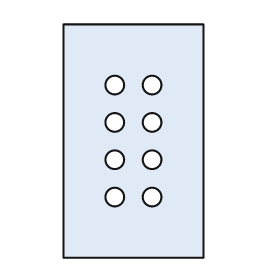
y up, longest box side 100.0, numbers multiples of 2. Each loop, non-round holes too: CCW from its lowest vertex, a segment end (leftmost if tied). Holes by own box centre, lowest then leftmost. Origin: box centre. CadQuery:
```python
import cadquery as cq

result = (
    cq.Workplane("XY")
    .moveTo(-30.0, -50.0)
    .lineTo(30.0, -50.0)
    .lineTo(30.0, 50.0)
    .lineTo(-30.0, 50.0)
    .close()
    .moveTo(-8.0, -24.0)
    .circle(4.0)
    .moveTo(8.0, -24.0)
    .circle(4.0)
    .moveTo(-8.0, -8.0)
    .circle(4.0)
    .moveTo(8.0, -8.0)
    .circle(4.0)
    .moveTo(-8.0, 8.0)
    .circle(4.0)
    .moveTo(8.0, 8.0)
    .circle(4.0)
    .moveTo(-8.0, 24.0)
    .circle(4.0)
    .moveTo(8.0, 24.0)
    .circle(4.0)
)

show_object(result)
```